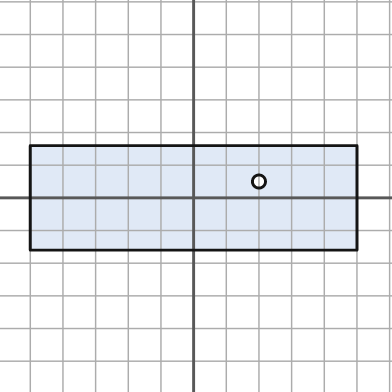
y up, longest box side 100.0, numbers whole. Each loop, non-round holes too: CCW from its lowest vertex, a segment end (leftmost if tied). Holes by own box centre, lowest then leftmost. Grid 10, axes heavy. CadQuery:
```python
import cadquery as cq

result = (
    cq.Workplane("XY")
    .moveTo(-50.0, -16.0)
    .lineTo(50.0, -16.0)
    .lineTo(50.0, 16.0)
    .lineTo(-50.0, 16.0)
    .close()
    .moveTo(20.0, 5.0)
    .circle(2.0)
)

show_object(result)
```